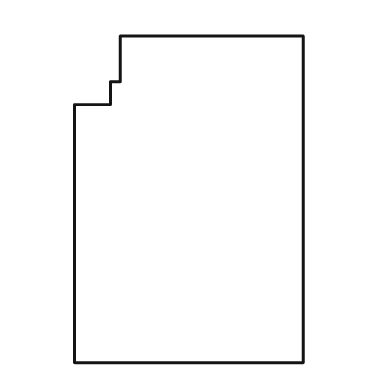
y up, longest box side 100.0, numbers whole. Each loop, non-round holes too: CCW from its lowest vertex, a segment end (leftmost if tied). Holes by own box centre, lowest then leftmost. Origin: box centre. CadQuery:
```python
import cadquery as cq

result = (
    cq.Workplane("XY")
    .moveTo(-35.0, -50.0)
    .lineTo(35.0, -50.0)
    .lineTo(35.0, 50.0)
    .lineTo(-21.0, 50.0)
    .lineTo(-21.0, 36.0)
    .lineTo(-24.0, 36.0)
    .lineTo(-24.0, 29.0)
    .lineTo(-35.0, 29.0)
    .close()
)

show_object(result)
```